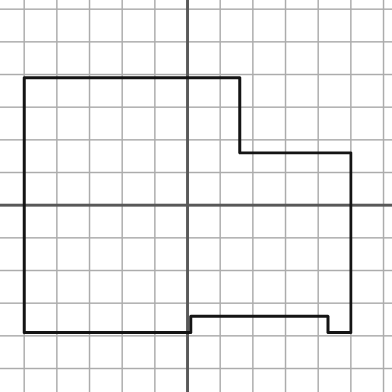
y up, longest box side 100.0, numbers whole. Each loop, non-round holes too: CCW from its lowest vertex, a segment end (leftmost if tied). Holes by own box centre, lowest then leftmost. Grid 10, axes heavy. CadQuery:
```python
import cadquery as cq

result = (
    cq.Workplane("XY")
    .moveTo(-50.0, -39.0)
    .lineTo(1.0, -39.0)
    .lineTo(1.0, -34.0)
    .lineTo(43.0, -34.0)
    .lineTo(43.0, -39.0)
    .lineTo(50.0, -39.0)
    .lineTo(50.0, 16.0)
    .lineTo(16.0, 16.0)
    .lineTo(16.0, 39.0)
    .lineTo(-50.0, 39.0)
    .close()
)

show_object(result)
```